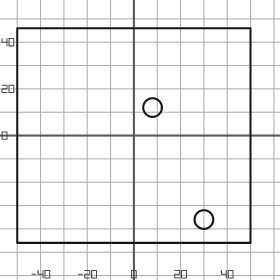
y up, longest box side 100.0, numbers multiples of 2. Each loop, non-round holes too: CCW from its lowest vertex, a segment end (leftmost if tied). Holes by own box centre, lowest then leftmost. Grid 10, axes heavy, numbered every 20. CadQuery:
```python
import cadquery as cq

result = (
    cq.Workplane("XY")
    .moveTo(-50.0, -46.0)
    .lineTo(50.0, -46.0)
    .lineTo(50.0, 46.0)
    .lineTo(-50.0, 46.0)
    .close()
    .moveTo(30.0, -36.0)
    .circle(4.0)
    .moveTo(8.0, 12.0)
    .circle(4.0)
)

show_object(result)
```